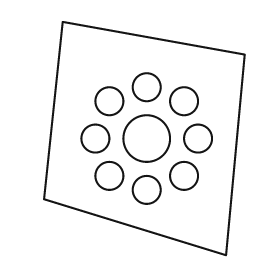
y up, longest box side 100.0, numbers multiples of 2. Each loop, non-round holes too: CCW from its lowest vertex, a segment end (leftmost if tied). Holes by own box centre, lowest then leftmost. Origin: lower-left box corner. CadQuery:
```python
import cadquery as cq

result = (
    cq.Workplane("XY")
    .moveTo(78.0, 0.0)
    .lineTo(86.0, 86.0)
    .lineTo(8.0, 100.0)
    .lineTo(0.0, 24.0)
    .close()
    .moveTo(44.0, 28.0)
    .circle(6.0)
    .moveTo(28.0, 34.0)
    .circle(6.0)
    .moveTo(60.0, 34.0)
    .circle(6.0)
    .moveTo(22.0, 50.0)
    .circle(6.0)
    .moveTo(44.0, 50.0)
    .circle(10.0)
    .moveTo(66.0, 50.0)
    .circle(6.0)
    .moveTo(28.0, 66.0)
    .circle(6.0)
    .moveTo(60.0, 66.0)
    .circle(6.0)
    .moveTo(44.0, 72.0)
    .circle(6.0)
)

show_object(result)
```